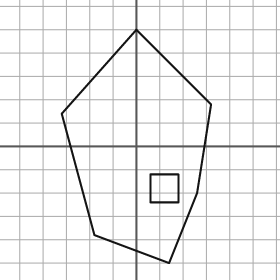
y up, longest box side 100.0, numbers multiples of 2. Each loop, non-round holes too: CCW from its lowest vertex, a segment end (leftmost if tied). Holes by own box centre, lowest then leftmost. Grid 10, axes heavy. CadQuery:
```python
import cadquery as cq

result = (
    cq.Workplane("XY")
    .moveTo(14.0, -50.0)
    .lineTo(26.0, -20.0)
    .lineTo(32.0, 18.0)
    .lineTo(0.0, 50.0)
    .lineTo(-32.0, 14.0)
    .lineTo(-18.0, -38.0)
    .close()
    .moveTo(6.0, -24.0)
    .lineTo(18.0, -24.0)
    .lineTo(18.0, -12.0)
    .lineTo(6.0, -12.0)
    .close()
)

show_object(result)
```